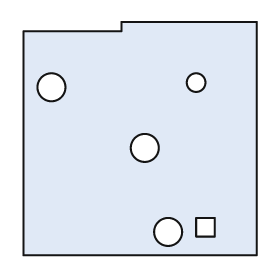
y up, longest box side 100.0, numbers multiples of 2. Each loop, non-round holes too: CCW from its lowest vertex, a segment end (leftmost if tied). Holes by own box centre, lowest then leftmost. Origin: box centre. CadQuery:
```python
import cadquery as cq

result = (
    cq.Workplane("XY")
    .moveTo(-50.0, -50.0)
    .lineTo(50.0, -50.0)
    .lineTo(50.0, 50.0)
    .lineTo(-8.0, 50.0)
    .lineTo(-8.0, 46.0)
    .lineTo(-50.0, 46.0)
    .close()
    .moveTo(12.0, -40.0)
    .circle(6.0)
    .moveTo(24.0, -42.0)
    .lineTo(32.0, -42.0)
    .lineTo(32.0, -34.0)
    .lineTo(24.0, -34.0)
    .close()
    .moveTo(2.0, -4.0)
    .circle(6.0)
    .moveTo(-38.0, 22.0)
    .circle(6.0)
    .moveTo(24.0, 24.0)
    .circle(4.0)
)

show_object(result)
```